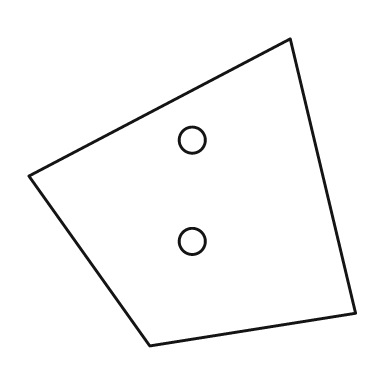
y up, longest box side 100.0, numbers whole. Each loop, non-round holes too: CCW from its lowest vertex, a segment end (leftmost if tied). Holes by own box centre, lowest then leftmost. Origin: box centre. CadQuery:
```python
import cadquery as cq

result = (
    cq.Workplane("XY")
    .moveTo(-13.0, -47.0)
    .lineTo(50.0, -37.0)
    .lineTo(30.0, 47.0)
    .lineTo(-50.0, 5.0)
    .close()
    .moveTo(0.0, -15.0)
    .circle(4.0)
    .moveTo(0.0, 16.0)
    .circle(4.0)
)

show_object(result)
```